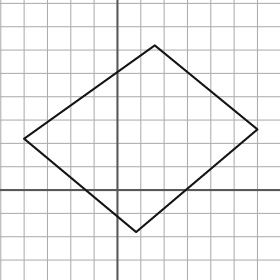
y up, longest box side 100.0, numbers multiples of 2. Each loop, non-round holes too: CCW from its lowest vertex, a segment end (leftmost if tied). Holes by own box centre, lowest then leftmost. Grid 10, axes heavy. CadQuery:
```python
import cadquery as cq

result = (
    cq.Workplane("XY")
    .moveTo(8.0, -18.0)
    .lineTo(60.0, 26.0)
    .lineTo(16.0, 62.0)
    .lineTo(-40.0, 22.0)
    .close()
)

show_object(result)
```